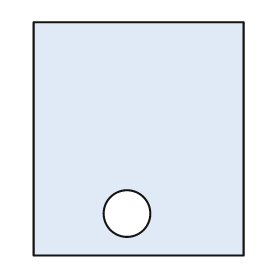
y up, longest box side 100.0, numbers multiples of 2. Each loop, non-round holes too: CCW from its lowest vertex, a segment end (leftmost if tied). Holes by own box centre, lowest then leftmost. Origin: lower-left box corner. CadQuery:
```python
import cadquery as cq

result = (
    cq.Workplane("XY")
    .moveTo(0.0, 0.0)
    .lineTo(90.0, 0.0)
    .lineTo(90.0, 100.0)
    .lineTo(0.0, 100.0)
    .close()
    .moveTo(40.0, 18.0)
    .circle(10.0)
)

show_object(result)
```